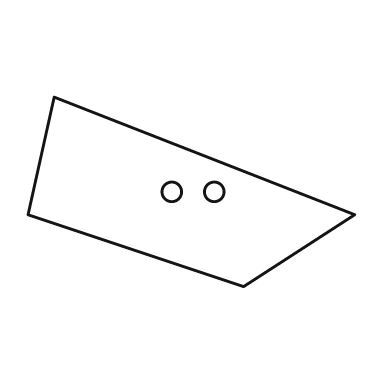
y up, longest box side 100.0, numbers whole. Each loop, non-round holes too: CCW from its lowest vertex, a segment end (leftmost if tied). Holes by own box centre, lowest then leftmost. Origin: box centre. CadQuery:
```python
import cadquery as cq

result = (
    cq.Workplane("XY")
    .moveTo(16.0, -29.0)
    .lineTo(50.0, -7.0)
    .lineTo(-42.0, 29.0)
    .lineTo(-50.0, -7.0)
    .close()
    .moveTo(-6.0, 0.0)
    .circle(3.0)
    .moveTo(7.0, 0.0)
    .circle(3.0)
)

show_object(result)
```